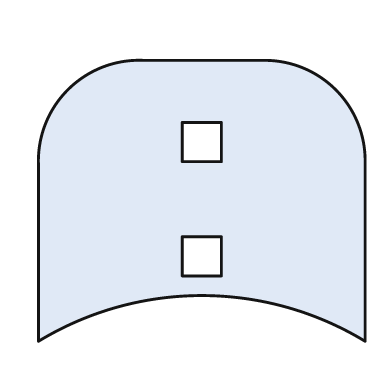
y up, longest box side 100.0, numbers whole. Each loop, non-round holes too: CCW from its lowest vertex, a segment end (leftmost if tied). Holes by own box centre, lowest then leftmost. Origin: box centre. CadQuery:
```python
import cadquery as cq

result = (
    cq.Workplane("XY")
    .moveTo(-50.0, -43.0)
    .threePointArc((0.0, -29.0), (50.0, -43.0))
    .lineTo(50.0, 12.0)
    .threePointArc((41.0, 34.0), (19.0, 43.0))
    .lineTo(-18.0, 43.0)
    .threePointArc((-41.0, 34.0), (-50.0, 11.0))
    .close()
    .moveTo(-6.0, -23.0)
    .lineTo(6.0, -23.0)
    .lineTo(6.0, -11.0)
    .lineTo(-6.0, -11.0)
    .close()
    .moveTo(-6.0, 12.0)
    .lineTo(6.0, 12.0)
    .lineTo(6.0, 24.0)
    .lineTo(-6.0, 24.0)
    .close()
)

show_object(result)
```